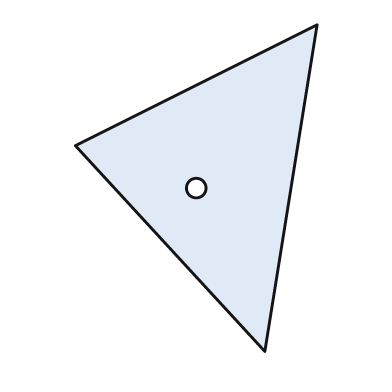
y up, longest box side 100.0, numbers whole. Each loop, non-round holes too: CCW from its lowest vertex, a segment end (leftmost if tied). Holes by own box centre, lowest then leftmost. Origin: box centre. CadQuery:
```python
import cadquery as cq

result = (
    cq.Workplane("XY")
    .moveTo(21.0, -50.0)
    .lineTo(37.0, 50.0)
    .lineTo(-37.0, 13.0)
    .close()
    .moveTo(0.0, 0.0)
    .circle(3.0)
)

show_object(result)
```